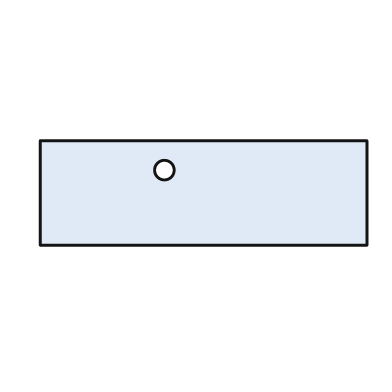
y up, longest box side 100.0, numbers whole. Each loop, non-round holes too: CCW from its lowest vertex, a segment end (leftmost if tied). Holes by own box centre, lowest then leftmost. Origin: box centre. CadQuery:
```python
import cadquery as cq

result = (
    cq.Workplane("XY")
    .moveTo(-50.0, -16.0)
    .lineTo(50.0, -16.0)
    .lineTo(50.0, 16.0)
    .lineTo(-50.0, 16.0)
    .close()
    .moveTo(-12.0, 7.0)
    .circle(3.0)
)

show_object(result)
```